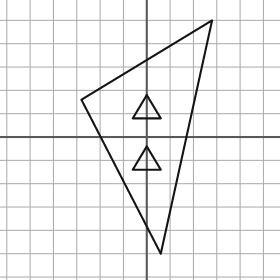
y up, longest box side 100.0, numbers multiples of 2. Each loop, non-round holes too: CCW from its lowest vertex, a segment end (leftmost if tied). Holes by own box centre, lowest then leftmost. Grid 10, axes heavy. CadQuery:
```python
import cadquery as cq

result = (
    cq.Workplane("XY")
    .moveTo(6.0, -50.0)
    .lineTo(28.0, 50.0)
    .lineTo(-28.0, 16.0)
    .close()
    .moveTo(-6.0, -14.0)
    .lineTo(6.0, -14.0)
    .lineTo(0.0, -4.0)
    .close()
    .moveTo(-6.0, 8.0)
    .lineTo(6.0, 8.0)
    .lineTo(0.0, 18.0)
    .close()
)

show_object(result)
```